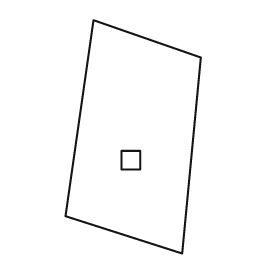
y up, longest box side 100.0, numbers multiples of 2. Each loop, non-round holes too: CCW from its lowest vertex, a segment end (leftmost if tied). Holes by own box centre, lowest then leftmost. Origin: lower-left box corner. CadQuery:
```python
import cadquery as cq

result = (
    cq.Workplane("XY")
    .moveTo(50.0, 0.0)
    .lineTo(58.0, 84.0)
    .lineTo(12.0, 100.0)
    .lineTo(0.0, 16.0)
    .close()
    .moveTo(24.0, 36.0)
    .lineTo(32.0, 36.0)
    .lineTo(32.0, 44.0)
    .lineTo(24.0, 44.0)
    .close()
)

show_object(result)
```